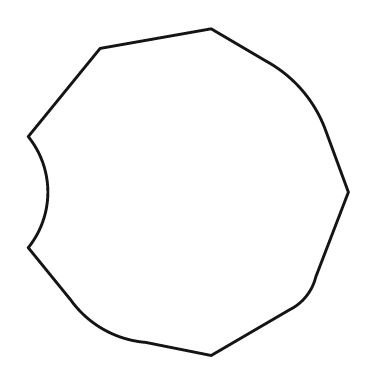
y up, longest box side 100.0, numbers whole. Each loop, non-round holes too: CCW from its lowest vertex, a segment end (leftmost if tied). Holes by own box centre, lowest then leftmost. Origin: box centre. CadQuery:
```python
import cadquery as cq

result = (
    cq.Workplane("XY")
    .moveTo(7.0, -50.0)
    .lineTo(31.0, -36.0)
    .threePointArc((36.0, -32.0), (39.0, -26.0))
    .lineTo(49.0, 0.0)
    .lineTo(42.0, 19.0)
    .threePointArc((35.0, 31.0), (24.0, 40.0))
    .lineTo(7.0, 50.0)
    .lineTo(-27.0, 44.0)
    .lineTo(-49.0, 17.0)
    .threePointArc((-43.0, 0.0), (-49.0, -17.0))
    .lineTo(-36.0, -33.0)
    .threePointArc((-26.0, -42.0), (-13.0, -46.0))
    .close()
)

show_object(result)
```